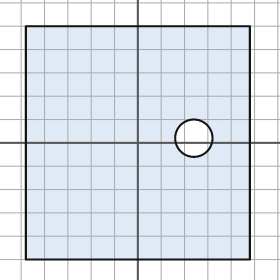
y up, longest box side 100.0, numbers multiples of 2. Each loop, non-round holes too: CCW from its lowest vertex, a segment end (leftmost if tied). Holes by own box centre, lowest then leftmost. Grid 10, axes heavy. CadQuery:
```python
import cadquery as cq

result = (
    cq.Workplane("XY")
    .moveTo(-48.0, -50.0)
    .lineTo(48.0, -50.0)
    .lineTo(48.0, 50.0)
    .lineTo(-48.0, 50.0)
    .close()
    .moveTo(24.0, 2.0)
    .circle(8.0)
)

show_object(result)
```